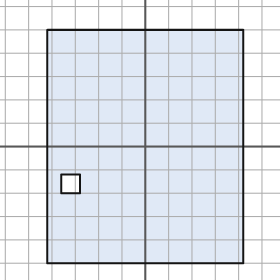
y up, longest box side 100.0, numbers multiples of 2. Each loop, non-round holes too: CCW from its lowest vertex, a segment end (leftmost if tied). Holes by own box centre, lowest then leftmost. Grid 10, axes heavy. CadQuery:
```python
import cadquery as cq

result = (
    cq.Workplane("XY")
    .moveTo(-42.0, -50.0)
    .lineTo(42.0, -50.0)
    .lineTo(42.0, 50.0)
    .lineTo(-42.0, 50.0)
    .close()
    .moveTo(-36.0, -20.0)
    .lineTo(-28.0, -20.0)
    .lineTo(-28.0, -12.0)
    .lineTo(-36.0, -12.0)
    .close()
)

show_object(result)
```